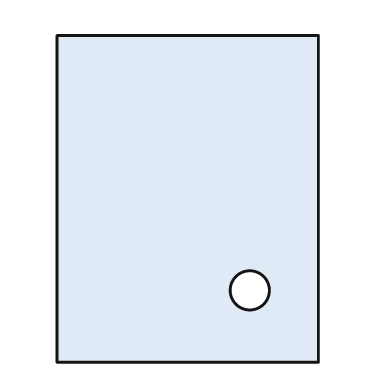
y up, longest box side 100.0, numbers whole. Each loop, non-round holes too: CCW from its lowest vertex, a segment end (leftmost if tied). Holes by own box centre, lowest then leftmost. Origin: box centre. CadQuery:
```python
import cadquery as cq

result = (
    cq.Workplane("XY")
    .moveTo(-40.0, -50.0)
    .lineTo(40.0, -50.0)
    .lineTo(40.0, 50.0)
    .lineTo(-40.0, 50.0)
    .close()
    .moveTo(19.0, -28.0)
    .circle(6.0)
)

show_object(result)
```